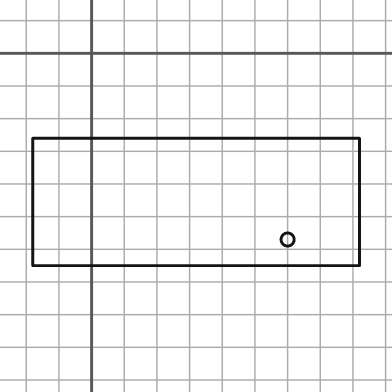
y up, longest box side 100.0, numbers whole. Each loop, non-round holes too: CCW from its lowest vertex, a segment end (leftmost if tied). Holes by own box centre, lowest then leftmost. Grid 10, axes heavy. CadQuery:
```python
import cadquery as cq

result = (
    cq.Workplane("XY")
    .moveTo(-18.0, -65.0)
    .lineTo(82.0, -65.0)
    .lineTo(82.0, -26.0)
    .lineTo(-18.0, -26.0)
    .close()
    .moveTo(60.0, -57.0)
    .circle(2.0)
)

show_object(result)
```